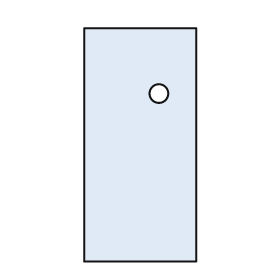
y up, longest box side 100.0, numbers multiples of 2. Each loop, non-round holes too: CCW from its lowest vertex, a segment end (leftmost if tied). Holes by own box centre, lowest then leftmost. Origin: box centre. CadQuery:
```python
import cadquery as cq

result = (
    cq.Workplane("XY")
    .moveTo(-24.0, -50.0)
    .lineTo(24.0, -50.0)
    .lineTo(24.0, 50.0)
    .lineTo(-24.0, 50.0)
    .close()
    .moveTo(8.0, 22.0)
    .circle(4.0)
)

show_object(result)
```